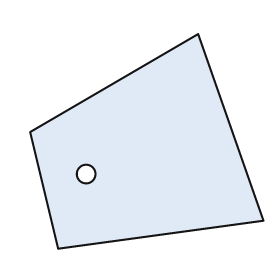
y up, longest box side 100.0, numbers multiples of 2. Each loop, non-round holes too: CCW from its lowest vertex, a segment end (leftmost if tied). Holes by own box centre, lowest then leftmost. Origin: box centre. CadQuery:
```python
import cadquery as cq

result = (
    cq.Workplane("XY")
    .moveTo(-38.0, -46.0)
    .lineTo(50.0, -34.0)
    .lineTo(22.0, 46.0)
    .lineTo(-50.0, 4.0)
    .close()
    .moveTo(-26.0, -14.0)
    .circle(4.0)
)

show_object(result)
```